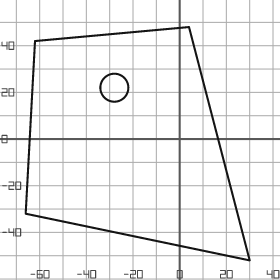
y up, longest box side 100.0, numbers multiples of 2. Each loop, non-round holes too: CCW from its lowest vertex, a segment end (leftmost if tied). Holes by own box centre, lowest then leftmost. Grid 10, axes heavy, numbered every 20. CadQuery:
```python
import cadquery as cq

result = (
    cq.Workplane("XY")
    .moveTo(30.0, -52.0)
    .lineTo(4.0, 48.0)
    .lineTo(-62.0, 42.0)
    .lineTo(-66.0, -32.0)
    .close()
    .moveTo(-28.0, 22.0)
    .circle(6.0)
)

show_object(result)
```